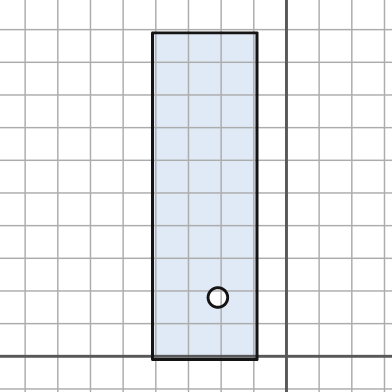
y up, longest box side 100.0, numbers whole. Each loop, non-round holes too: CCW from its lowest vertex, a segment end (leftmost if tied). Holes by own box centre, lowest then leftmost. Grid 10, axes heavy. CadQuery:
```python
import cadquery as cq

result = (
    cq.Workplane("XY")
    .moveTo(-41.0, -1.0)
    .lineTo(-9.0, -1.0)
    .lineTo(-9.0, 99.0)
    .lineTo(-41.0, 99.0)
    .close()
    .moveTo(-21.0, 18.0)
    .circle(3.0)
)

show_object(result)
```